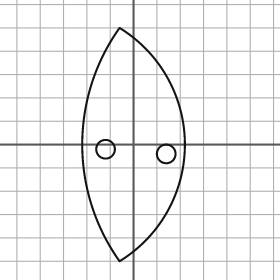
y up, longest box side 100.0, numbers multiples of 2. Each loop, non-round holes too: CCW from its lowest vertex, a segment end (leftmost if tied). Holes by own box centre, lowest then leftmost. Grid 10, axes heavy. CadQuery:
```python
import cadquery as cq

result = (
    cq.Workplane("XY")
    .moveTo(-6.0, -50.0)
    .threePointArc((22.0, 0.0), (-6.0, 50.0))
    .threePointArc((-22.0, 0.0), (-6.0, -50.0))
    .close()
    .moveTo(14.0, -4.0)
    .circle(4.0)
    .moveTo(-12.0, -2.0)
    .circle(4.0)
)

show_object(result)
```